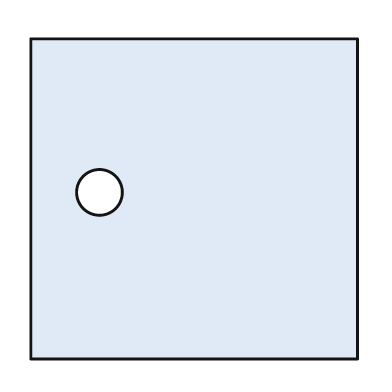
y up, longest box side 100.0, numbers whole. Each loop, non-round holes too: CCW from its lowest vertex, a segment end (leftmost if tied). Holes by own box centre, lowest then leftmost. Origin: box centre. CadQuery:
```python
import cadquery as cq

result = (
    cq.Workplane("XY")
    .moveTo(-50.0, -49.0)
    .lineTo(50.0, -49.0)
    .lineTo(50.0, 49.0)
    .lineTo(-50.0, 49.0)
    .close()
    .moveTo(-29.0, 2.0)
    .circle(7.0)
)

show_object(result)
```